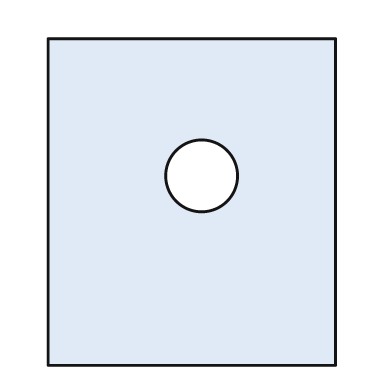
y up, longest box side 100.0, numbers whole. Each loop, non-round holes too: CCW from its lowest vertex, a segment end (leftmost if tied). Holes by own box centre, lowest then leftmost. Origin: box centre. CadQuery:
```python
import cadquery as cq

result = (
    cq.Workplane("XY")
    .moveTo(-44.0, -50.0)
    .lineTo(44.0, -50.0)
    .lineTo(44.0, 50.0)
    .lineTo(-44.0, 50.0)
    .close()
    .moveTo(3.0, 8.0)
    .circle(11.0)
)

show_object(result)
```